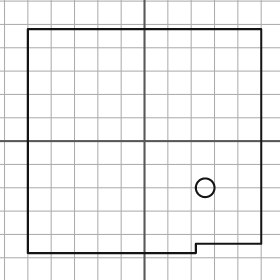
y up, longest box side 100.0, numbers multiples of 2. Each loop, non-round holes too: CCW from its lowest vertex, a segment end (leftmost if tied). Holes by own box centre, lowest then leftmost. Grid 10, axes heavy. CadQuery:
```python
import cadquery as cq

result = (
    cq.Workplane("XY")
    .moveTo(-50.0, -48.0)
    .lineTo(22.0, -48.0)
    .lineTo(22.0, -44.0)
    .lineTo(50.0, -44.0)
    .lineTo(50.0, 48.0)
    .lineTo(-50.0, 48.0)
    .close()
    .moveTo(26.0, -20.0)
    .circle(4.0)
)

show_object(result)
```